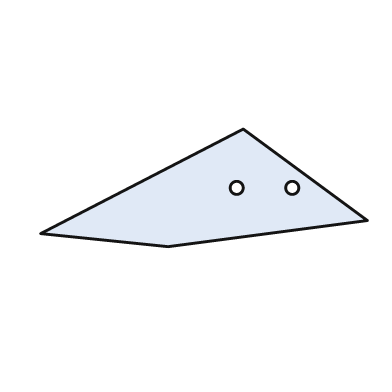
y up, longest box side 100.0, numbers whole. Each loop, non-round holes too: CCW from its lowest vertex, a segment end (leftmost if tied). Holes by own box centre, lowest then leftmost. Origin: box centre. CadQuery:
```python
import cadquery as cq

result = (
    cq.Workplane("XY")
    .moveTo(-11.0, -18.0)
    .lineTo(50.0, -10.0)
    .lineTo(12.0, 18.0)
    .lineTo(-50.0, -14.0)
    .close()
    .moveTo(10.0, 0.0)
    .circle(2.0)
    .moveTo(27.0, 0.0)
    .circle(2.0)
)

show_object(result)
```